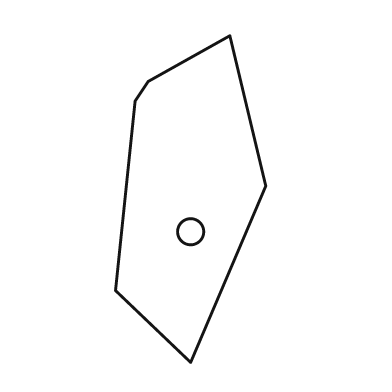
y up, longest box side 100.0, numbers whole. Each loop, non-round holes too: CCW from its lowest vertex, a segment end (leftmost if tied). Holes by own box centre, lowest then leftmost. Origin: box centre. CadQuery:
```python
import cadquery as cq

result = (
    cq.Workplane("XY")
    .moveTo(0.0, -50.0)
    .lineTo(23.0, 4.0)
    .lineTo(12.0, 50.0)
    .lineTo(-13.0, 36.0)
    .lineTo(-17.0, 30.0)
    .lineTo(-23.0, -28.0)
    .close()
    .moveTo(0.0, -10.0)
    .circle(4.0)
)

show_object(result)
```